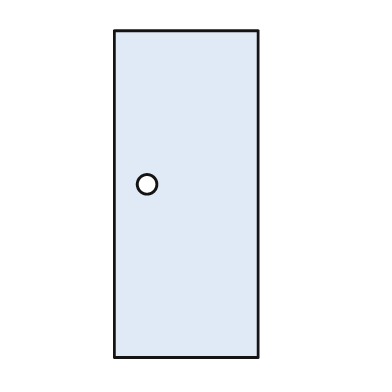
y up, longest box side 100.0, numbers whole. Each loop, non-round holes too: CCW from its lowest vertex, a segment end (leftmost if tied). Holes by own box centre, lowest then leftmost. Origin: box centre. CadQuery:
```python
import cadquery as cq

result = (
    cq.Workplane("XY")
    .moveTo(-22.0, -50.0)
    .lineTo(22.0, -50.0)
    .lineTo(22.0, 50.0)
    .lineTo(-22.0, 50.0)
    .close()
    .moveTo(-12.0, 3.0)
    .circle(3.0)
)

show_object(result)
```